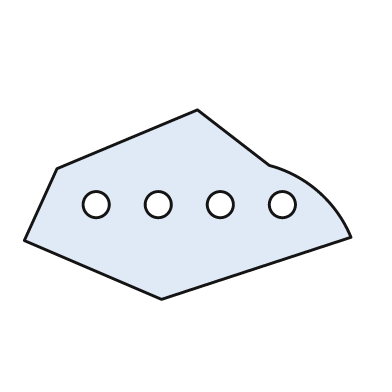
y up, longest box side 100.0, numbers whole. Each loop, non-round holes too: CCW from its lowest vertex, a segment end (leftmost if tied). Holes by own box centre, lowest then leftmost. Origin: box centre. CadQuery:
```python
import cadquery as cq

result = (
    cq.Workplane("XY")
    .moveTo(-8.0, -29.0)
    .lineTo(50.0, -10.0)
    .threePointArc((40.0, 4.0), (25.0, 12.0))
    .lineTo(3.0, 29.0)
    .lineTo(-40.0, 11.0)
    .lineTo(-50.0, -11.0)
    .close()
    .moveTo(-28.0, 0.0)
    .circle(4.0)
    .moveTo(-9.0, 0.0)
    .circle(4.0)
    .moveTo(10.0, 0.0)
    .circle(4.0)
    .moveTo(29.0, 0.0)
    .circle(4.0)
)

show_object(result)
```